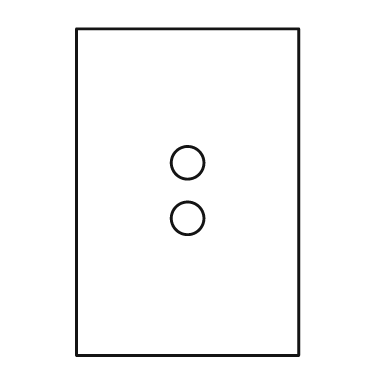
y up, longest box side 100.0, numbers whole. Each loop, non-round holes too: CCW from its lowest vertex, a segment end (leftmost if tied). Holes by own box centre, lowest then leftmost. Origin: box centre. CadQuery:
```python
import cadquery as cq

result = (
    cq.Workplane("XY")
    .moveTo(-34.0, -50.0)
    .lineTo(34.0, -50.0)
    .lineTo(34.0, 50.0)
    .lineTo(-34.0, 50.0)
    .close()
    .moveTo(0.0, -8.0)
    .circle(5.0)
    .moveTo(0.0, 9.0)
    .circle(5.0)
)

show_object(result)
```